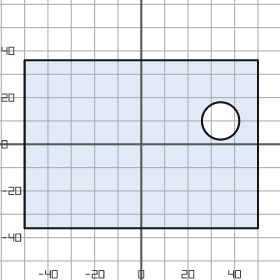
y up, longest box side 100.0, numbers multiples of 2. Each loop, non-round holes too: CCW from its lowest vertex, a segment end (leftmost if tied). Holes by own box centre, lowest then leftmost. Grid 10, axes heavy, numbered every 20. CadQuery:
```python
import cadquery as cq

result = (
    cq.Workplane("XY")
    .moveTo(-50.0, -36.0)
    .lineTo(50.0, -36.0)
    .lineTo(50.0, 36.0)
    .lineTo(-50.0, 36.0)
    .close()
    .moveTo(34.0, 10.0)
    .circle(8.0)
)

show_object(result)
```